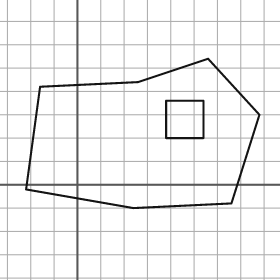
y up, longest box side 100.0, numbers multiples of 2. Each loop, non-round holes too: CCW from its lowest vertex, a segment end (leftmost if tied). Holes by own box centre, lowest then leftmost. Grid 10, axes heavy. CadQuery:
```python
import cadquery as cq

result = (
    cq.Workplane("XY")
    .moveTo(24.0, -10.0)
    .lineTo(66.0, -8.0)
    .lineTo(78.0, 30.0)
    .lineTo(56.0, 54.0)
    .lineTo(26.0, 44.0)
    .lineTo(-16.0, 42.0)
    .lineTo(-22.0, -2.0)
    .close()
    .moveTo(38.0, 20.0)
    .lineTo(54.0, 20.0)
    .lineTo(54.0, 36.0)
    .lineTo(38.0, 36.0)
    .close()
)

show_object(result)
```